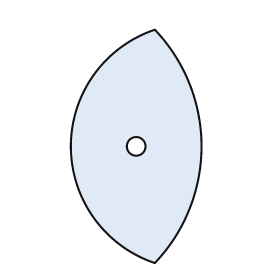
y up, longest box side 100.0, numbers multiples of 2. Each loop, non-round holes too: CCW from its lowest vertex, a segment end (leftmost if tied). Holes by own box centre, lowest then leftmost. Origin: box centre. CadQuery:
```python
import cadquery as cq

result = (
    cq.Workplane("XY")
    .moveTo(8.0, -50.0)
    .threePointArc((28.0, 0.0), (8.0, 50.0))
    .threePointArc((-28.0, 0.0), (8.0, -50.0))
    .close()
    .moveTo(0.0, 0.0)
    .circle(4.0)
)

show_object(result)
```